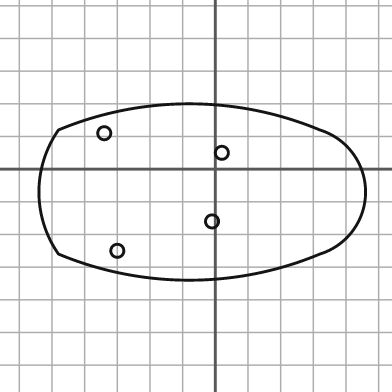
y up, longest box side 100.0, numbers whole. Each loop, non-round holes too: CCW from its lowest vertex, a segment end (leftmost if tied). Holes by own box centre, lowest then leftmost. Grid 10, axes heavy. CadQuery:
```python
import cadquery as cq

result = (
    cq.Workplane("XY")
    .moveTo(-48.0, -26.0)
    .threePointArc((-8.0, -34.0), (32.0, -26.0))
    .threePointArc((46.0, -7.0), (32.0, 12.0))
    .threePointArc((-8.0, 20.0), (-48.0, 12.0))
    .threePointArc((-54.0, -7.0), (-48.0, -26.0))
    .close()
    .moveTo(-30.0, -25.0)
    .circle(2.0)
    .moveTo(-1.0, -16.0)
    .circle(2.0)
    .moveTo(2.0, 5.0)
    .circle(2.0)
    .moveTo(-34.0, 11.0)
    .circle(2.0)
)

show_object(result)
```